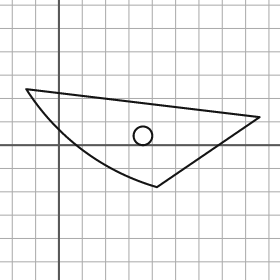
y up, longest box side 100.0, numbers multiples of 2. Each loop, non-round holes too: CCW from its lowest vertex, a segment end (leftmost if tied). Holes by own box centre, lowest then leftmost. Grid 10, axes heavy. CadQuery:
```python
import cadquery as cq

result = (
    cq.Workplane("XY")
    .moveTo(42.0, -18.0)
    .lineTo(86.0, 12.0)
    .lineTo(-14.0, 24.0)
    .threePointArc((10.0, -2.0), (42.0, -18.0))
    .close()
    .moveTo(36.0, 4.0)
    .circle(4.0)
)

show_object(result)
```